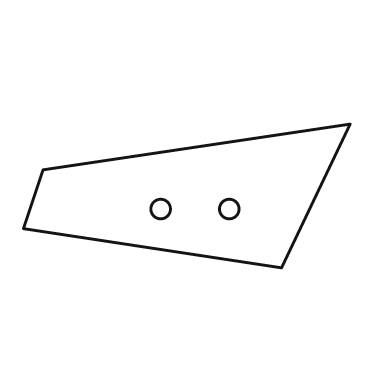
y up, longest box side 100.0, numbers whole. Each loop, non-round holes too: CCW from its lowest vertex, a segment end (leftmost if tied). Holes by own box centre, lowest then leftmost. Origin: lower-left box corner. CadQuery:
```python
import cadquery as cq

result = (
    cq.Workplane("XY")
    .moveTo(79.0, 0.0)
    .lineTo(100.0, 44.0)
    .lineTo(6.0, 30.0)
    .lineTo(0.0, 12.0)
    .close()
    .moveTo(42.0, 18.0)
    .circle(3.0)
    .moveTo(63.0, 18.0)
    .circle(3.0)
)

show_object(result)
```